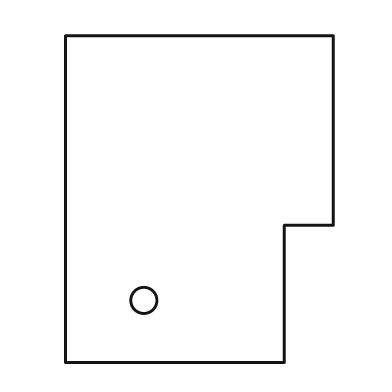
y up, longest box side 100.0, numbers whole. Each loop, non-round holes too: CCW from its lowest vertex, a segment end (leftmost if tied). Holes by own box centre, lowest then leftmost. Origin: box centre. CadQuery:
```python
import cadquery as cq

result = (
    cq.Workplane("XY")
    .moveTo(-41.0, -50.0)
    .lineTo(26.0, -50.0)
    .lineTo(26.0, -8.0)
    .lineTo(41.0, -8.0)
    .lineTo(41.0, 50.0)
    .lineTo(-41.0, 50.0)
    .close()
    .moveTo(-17.0, -31.0)
    .circle(4.0)
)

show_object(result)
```